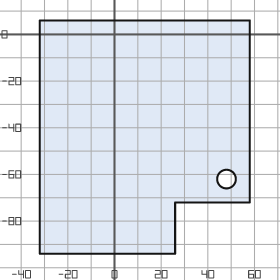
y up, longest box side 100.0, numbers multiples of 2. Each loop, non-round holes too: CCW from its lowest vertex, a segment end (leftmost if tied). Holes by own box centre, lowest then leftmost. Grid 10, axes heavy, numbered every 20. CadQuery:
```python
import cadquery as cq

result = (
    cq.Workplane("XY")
    .moveTo(-32.0, -94.0)
    .lineTo(26.0, -94.0)
    .lineTo(26.0, -72.0)
    .lineTo(58.0, -72.0)
    .lineTo(58.0, 6.0)
    .lineTo(-32.0, 6.0)
    .close()
    .moveTo(48.0, -62.0)
    .circle(4.0)
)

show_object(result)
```